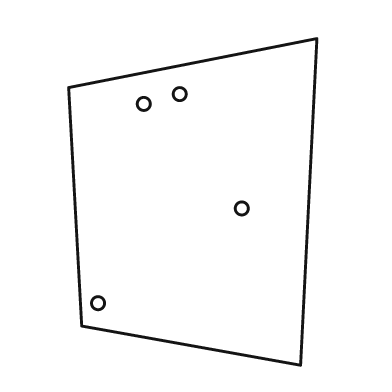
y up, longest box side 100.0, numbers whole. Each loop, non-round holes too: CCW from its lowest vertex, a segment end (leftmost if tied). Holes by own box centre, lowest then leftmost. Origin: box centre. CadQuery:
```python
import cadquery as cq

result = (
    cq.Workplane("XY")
    .moveTo(33.0, -50.0)
    .lineTo(38.0, 50.0)
    .lineTo(-38.0, 35.0)
    .lineTo(-34.0, -38.0)
    .close()
    .moveTo(-29.0, -31.0)
    .circle(2.0)
    .moveTo(15.0, -2.0)
    .circle(2.0)
    .moveTo(-15.0, 30.0)
    .circle(2.0)
    .moveTo(-4.0, 33.0)
    .circle(2.0)
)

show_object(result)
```